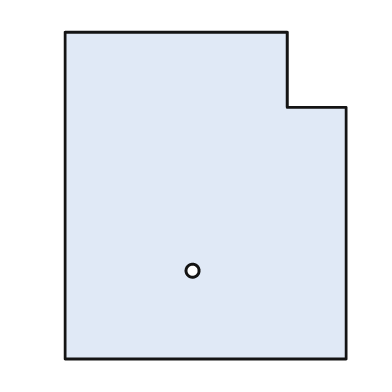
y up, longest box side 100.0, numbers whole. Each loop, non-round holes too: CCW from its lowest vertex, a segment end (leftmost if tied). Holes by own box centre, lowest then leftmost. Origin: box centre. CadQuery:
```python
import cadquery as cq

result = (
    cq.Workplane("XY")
    .moveTo(-43.0, -50.0)
    .lineTo(43.0, -50.0)
    .lineTo(43.0, 27.0)
    .lineTo(25.0, 27.0)
    .lineTo(25.0, 50.0)
    .lineTo(-43.0, 50.0)
    .close()
    .moveTo(-4.0, -23.0)
    .circle(2.0)
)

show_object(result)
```